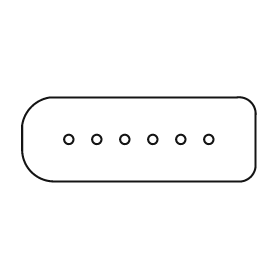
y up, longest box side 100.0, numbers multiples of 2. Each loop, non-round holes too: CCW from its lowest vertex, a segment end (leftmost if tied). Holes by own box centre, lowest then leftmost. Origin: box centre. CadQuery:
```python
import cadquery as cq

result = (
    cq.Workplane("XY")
    .moveTo(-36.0, -18.0)
    .lineTo(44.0, -18.0)
    .threePointArc((48.0, -16.0), (50.0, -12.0))
    .lineTo(50.0, 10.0)
    .threePointArc((48.0, 16.0), (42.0, 18.0))
    .lineTo(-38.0, 18.0)
    .threePointArc((-46.0, 14.0), (-50.0, 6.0))
    .lineTo(-50.0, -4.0)
    .threePointArc((-46.0, -14.0), (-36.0, -18.0))
    .close()
    .moveTo(-30.0, 0.0)
    .circle(2.0)
    .moveTo(-18.0, 0.0)
    .circle(2.0)
    .moveTo(-6.0, 0.0)
    .circle(2.0)
    .moveTo(6.0, 0.0)
    .circle(2.0)
    .moveTo(18.0, 0.0)
    .circle(2.0)
    .moveTo(30.0, 0.0)
    .circle(2.0)
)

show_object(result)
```